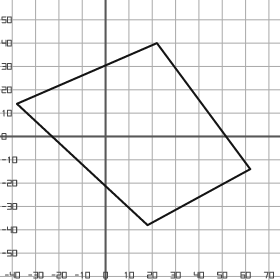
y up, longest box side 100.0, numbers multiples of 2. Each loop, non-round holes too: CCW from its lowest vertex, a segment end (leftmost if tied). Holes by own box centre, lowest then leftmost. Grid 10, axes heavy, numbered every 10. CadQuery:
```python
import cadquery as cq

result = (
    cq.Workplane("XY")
    .moveTo(18.0, -38.0)
    .lineTo(62.0, -14.0)
    .lineTo(22.0, 40.0)
    .lineTo(-38.0, 14.0)
    .close()
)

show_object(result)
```